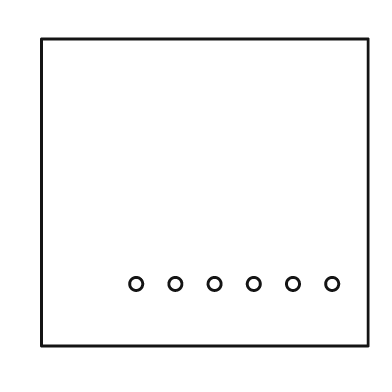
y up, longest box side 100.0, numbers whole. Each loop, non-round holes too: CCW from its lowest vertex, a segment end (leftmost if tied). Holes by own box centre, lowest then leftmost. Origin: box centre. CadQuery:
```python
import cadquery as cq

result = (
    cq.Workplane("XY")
    .moveTo(-50.0, -47.0)
    .lineTo(50.0, -47.0)
    .lineTo(50.0, 47.0)
    .lineTo(-50.0, 47.0)
    .close()
    .moveTo(-21.0, -28.0)
    .circle(2.0)
    .moveTo(-9.0, -28.0)
    .circle(2.0)
    .moveTo(3.0, -28.0)
    .circle(2.0)
    .moveTo(15.0, -28.0)
    .circle(2.0)
    .moveTo(27.0, -28.0)
    .circle(2.0)
    .moveTo(39.0, -28.0)
    .circle(2.0)
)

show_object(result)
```